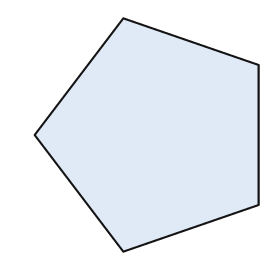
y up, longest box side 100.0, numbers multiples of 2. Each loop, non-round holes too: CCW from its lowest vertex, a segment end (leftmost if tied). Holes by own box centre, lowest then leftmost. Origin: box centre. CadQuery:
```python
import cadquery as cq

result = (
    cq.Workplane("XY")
    .moveTo(-10.0, -50.0)
    .lineTo(48.0, -30.0)
    .lineTo(48.0, 30.0)
    .lineTo(-10.0, 50.0)
    .lineTo(-48.0, 0.0)
    .close()
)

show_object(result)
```